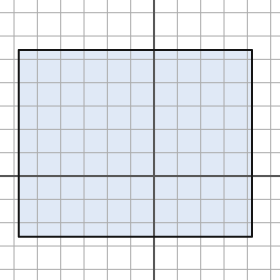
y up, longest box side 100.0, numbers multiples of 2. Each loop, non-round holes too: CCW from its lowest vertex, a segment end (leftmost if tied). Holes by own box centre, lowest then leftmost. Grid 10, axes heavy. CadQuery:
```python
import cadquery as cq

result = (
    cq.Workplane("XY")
    .moveTo(-58.0, -26.0)
    .lineTo(42.0, -26.0)
    .lineTo(42.0, 54.0)
    .lineTo(-58.0, 54.0)
    .close()
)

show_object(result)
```